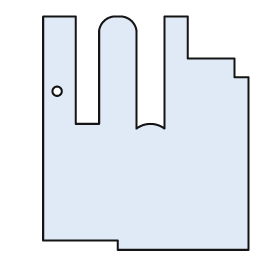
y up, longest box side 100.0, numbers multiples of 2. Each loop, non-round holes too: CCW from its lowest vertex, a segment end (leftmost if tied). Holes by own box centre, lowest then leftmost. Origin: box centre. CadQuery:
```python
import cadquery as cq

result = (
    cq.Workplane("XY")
    .moveTo(-12.0, -50.0)
    .lineTo(44.0, -50.0)
    .lineTo(44.0, 24.0)
    .lineTo(38.0, 24.0)
    .lineTo(38.0, 32.0)
    .lineTo(18.0, 32.0)
    .lineTo(18.0, 50.0)
    .lineTo(8.0, 50.0)
    .lineTo(8.0, 2.0)
    .threePointArc((2.0, 4.0), (-4.0, 2.0))
    .lineTo(-4.0, 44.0)
    .threePointArc((-6.0, 48.0), (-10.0, 50.0))
    .lineTo(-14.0, 50.0)
    .threePointArc((-18.0, 48.0), (-20.0, 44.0))
    .lineTo(-20.0, 4.0)
    .lineTo(-30.0, 4.0)
    .lineTo(-30.0, 50.0)
    .lineTo(-44.0, 50.0)
    .lineTo(-44.0, -46.0)
    .lineTo(-12.0, -46.0)
    .close()
    .moveTo(-38.0, 18.0)
    .circle(2.0)
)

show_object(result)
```